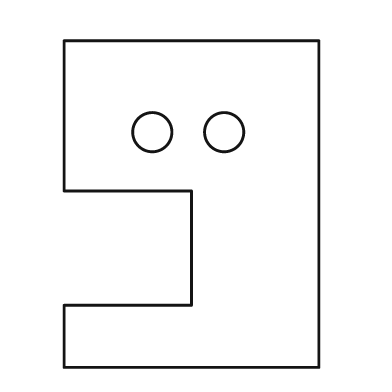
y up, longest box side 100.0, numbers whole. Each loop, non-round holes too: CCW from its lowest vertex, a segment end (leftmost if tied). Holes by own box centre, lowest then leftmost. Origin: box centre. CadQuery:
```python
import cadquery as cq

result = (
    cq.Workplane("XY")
    .moveTo(-39.0, -50.0)
    .lineTo(39.0, -50.0)
    .lineTo(39.0, 50.0)
    .lineTo(-39.0, 50.0)
    .lineTo(-39.0, 4.0)
    .lineTo(0.0, 4.0)
    .lineTo(0.0, -31.0)
    .lineTo(-39.0, -31.0)
    .close()
    .moveTo(-12.0, 22.0)
    .circle(6.0)
    .moveTo(10.0, 22.0)
    .circle(6.0)
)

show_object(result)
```